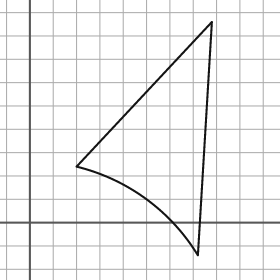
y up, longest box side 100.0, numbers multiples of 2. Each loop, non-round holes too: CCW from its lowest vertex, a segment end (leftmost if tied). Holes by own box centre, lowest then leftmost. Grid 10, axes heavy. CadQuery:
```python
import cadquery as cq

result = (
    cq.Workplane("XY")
    .moveTo(72.0, -14.0)
    .lineTo(78.0, 86.0)
    .lineTo(20.0, 24.0)
    .threePointArc((50.0, 10.0), (72.0, -14.0))
    .close()
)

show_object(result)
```